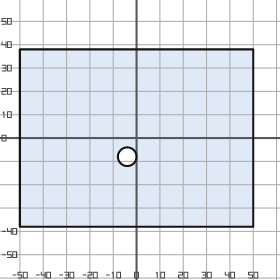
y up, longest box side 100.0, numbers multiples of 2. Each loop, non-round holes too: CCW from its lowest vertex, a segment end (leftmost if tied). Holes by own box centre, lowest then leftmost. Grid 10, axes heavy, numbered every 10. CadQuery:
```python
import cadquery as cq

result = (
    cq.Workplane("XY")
    .moveTo(-50.0, -38.0)
    .lineTo(50.0, -38.0)
    .lineTo(50.0, 38.0)
    .lineTo(-50.0, 38.0)
    .close()
    .moveTo(-4.0, -8.0)
    .circle(4.0)
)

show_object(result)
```